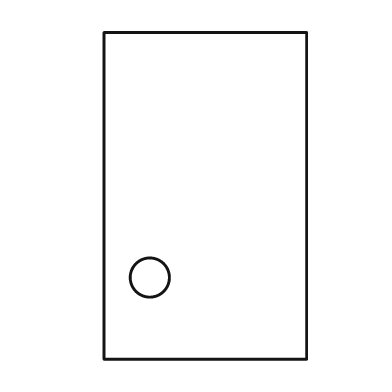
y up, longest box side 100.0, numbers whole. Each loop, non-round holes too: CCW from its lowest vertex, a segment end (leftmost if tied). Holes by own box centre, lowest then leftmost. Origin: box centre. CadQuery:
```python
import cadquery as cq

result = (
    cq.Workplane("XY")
    .moveTo(-31.0, -50.0)
    .lineTo(31.0, -50.0)
    .lineTo(31.0, 50.0)
    .lineTo(-31.0, 50.0)
    .close()
    .moveTo(-17.0, -25.0)
    .circle(6.0)
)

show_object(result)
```